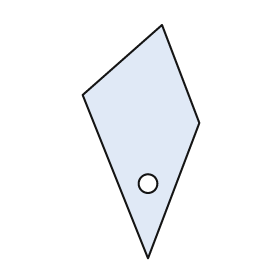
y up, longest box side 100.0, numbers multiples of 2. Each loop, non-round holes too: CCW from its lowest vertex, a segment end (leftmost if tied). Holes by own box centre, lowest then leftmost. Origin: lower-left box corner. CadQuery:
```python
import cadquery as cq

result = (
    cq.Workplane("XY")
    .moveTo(28.0, 0.0)
    .lineTo(50.0, 58.0)
    .lineTo(34.0, 100.0)
    .lineTo(0.0, 70.0)
    .close()
    .moveTo(28.0, 32.0)
    .circle(4.0)
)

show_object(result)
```